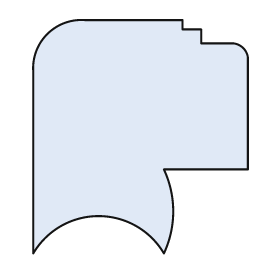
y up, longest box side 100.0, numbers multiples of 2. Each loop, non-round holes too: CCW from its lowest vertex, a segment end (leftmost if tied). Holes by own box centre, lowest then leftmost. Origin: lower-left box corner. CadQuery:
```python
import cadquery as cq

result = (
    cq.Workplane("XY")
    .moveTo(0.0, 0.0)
    .threePointArc((28.0, 16.0), (56.0, 0.0))
    .threePointArc((60.0, 18.0), (56.0, 36.0))
    .lineTo(92.0, 36.0)
    .lineTo(92.0, 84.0)
    .threePointArc((90.0, 88.0), (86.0, 90.0))
    .lineTo(72.0, 90.0)
    .lineTo(72.0, 96.0)
    .lineTo(64.0, 96.0)
    .lineTo(64.0, 100.0)
    .lineTo(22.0, 100.0)
    .threePointArc((6.0, 94.0), (0.0, 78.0))
    .close()
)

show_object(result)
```